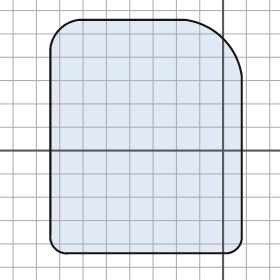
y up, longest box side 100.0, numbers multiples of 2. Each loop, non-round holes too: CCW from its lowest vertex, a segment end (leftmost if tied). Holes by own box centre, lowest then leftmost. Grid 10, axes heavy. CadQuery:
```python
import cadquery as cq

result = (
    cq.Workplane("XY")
    .moveTo(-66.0, -44.0)
    .lineTo(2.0, -44.0)
    .threePointArc((6.0, -42.0), (8.0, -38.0))
    .lineTo(8.0, 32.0)
    .threePointArc((0.0, 48.0), (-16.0, 56.0))
    .lineTo(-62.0, 56.0)
    .threePointArc((-70.0, 52.0), (-74.0, 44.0))
    .lineTo(-74.0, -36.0)
    .threePointArc((-72.0, -42.0), (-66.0, -44.0))
    .close()
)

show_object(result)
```